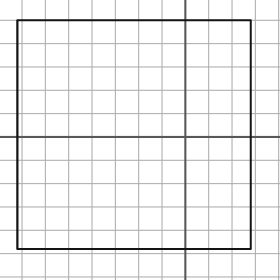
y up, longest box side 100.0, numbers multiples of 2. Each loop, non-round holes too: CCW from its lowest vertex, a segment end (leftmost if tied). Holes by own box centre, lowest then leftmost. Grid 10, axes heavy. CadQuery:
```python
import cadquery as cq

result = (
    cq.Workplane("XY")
    .moveTo(-72.0, -48.0)
    .lineTo(28.0, -48.0)
    .lineTo(28.0, 50.0)
    .lineTo(-72.0, 50.0)
    .close()
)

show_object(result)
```